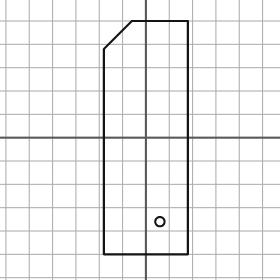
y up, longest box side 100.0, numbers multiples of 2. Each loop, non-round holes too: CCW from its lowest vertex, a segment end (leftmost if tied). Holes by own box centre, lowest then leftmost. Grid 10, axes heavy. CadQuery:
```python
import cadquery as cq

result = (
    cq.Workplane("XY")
    .moveTo(-18.0, -50.0)
    .lineTo(18.0, -50.0)
    .lineTo(18.0, 50.0)
    .lineTo(-6.0, 50.0)
    .lineTo(-18.0, 38.0)
    .close()
    .moveTo(6.0, -36.0)
    .circle(2.0)
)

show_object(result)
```